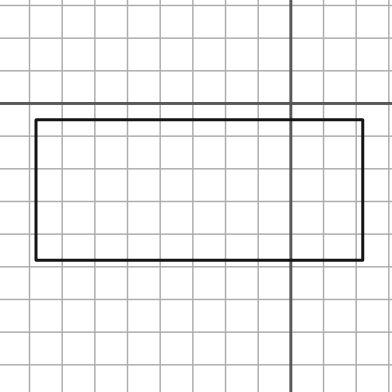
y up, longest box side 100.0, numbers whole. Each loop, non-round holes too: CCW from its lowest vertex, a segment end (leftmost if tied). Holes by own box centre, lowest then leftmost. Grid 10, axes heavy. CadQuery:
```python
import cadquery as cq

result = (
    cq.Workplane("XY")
    .moveTo(-78.0, -48.0)
    .lineTo(22.0, -48.0)
    .lineTo(22.0, -5.0)
    .lineTo(-78.0, -5.0)
    .close()
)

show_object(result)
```